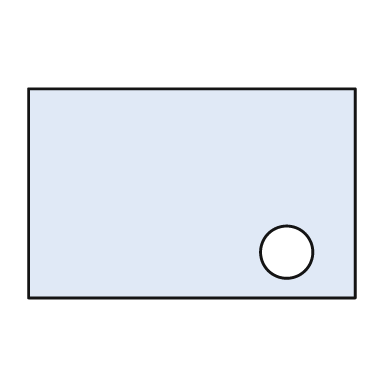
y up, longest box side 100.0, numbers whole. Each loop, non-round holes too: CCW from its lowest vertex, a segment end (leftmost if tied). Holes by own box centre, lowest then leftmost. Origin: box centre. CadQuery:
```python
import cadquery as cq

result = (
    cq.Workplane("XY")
    .moveTo(-50.0, -32.0)
    .lineTo(50.0, -32.0)
    .lineTo(50.0, 32.0)
    .lineTo(-50.0, 32.0)
    .close()
    .moveTo(29.0, -18.0)
    .circle(8.0)
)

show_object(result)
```